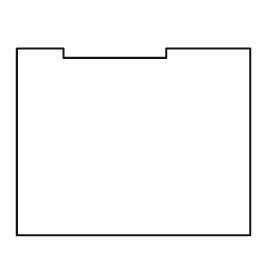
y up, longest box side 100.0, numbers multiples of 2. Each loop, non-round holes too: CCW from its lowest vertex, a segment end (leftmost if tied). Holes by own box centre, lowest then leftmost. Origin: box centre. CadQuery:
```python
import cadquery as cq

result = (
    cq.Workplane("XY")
    .moveTo(-50.0, -40.0)
    .lineTo(50.0, -40.0)
    .lineTo(50.0, 40.0)
    .lineTo(14.0, 40.0)
    .lineTo(14.0, 36.0)
    .lineTo(-30.0, 36.0)
    .lineTo(-30.0, 40.0)
    .lineTo(-50.0, 40.0)
    .close()
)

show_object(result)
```